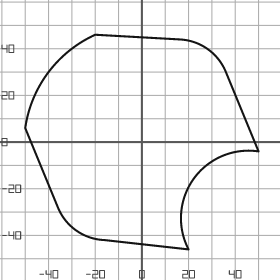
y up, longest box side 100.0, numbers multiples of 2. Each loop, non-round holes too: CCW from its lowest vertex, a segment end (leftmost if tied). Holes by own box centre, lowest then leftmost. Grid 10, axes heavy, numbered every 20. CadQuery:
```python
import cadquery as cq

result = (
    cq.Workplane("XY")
    .moveTo(20.0, -46.0)
    .threePointArc((22.0, -16.0), (50.0, -4.0))
    .lineTo(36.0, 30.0)
    .threePointArc((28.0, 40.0), (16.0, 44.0))
    .lineTo(-20.0, 46.0)
    .threePointArc((-40.0, 30.0), (-50.0, 6.0))
    .lineTo(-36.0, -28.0)
    .threePointArc((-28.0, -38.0), (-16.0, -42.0))
    .close()
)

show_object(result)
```